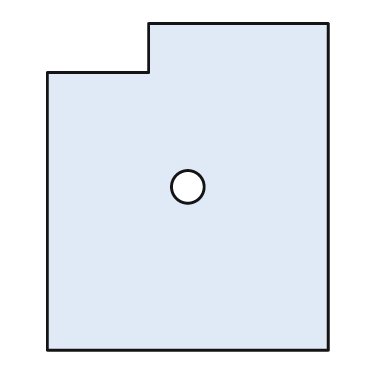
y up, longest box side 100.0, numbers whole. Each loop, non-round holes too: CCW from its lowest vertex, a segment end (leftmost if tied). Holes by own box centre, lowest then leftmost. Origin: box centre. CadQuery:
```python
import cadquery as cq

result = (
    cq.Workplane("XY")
    .moveTo(-43.0, -50.0)
    .lineTo(43.0, -50.0)
    .lineTo(43.0, 50.0)
    .lineTo(-12.0, 50.0)
    .lineTo(-12.0, 35.0)
    .lineTo(-43.0, 35.0)
    .close()
    .moveTo(0.0, 0.0)
    .circle(5.0)
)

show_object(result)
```